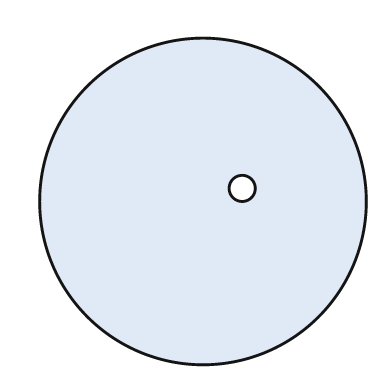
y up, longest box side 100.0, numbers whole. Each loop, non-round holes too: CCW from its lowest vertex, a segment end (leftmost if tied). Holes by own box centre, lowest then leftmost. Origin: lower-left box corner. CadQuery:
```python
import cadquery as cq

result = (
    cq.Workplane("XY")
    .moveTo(50.0, 50.0)
    .circle(50.0)
    .moveTo(62.0, 54.0)
    .circle(4.0)
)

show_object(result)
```